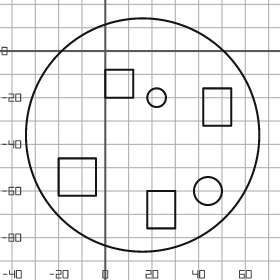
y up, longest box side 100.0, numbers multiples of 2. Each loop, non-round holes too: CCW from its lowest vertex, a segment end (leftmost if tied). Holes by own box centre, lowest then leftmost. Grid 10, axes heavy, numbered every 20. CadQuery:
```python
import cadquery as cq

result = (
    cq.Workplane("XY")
    .moveTo(16.0, -36.0)
    .circle(50.0)
    .moveTo(18.0, -76.0)
    .lineTo(30.0, -76.0)
    .lineTo(30.0, -60.0)
    .lineTo(18.0, -60.0)
    .close()
    .moveTo(44.0, -60.0)
    .circle(6.0)
    .moveTo(-20.0, -62.0)
    .lineTo(-4.0, -62.0)
    .lineTo(-4.0, -46.0)
    .lineTo(-20.0, -46.0)
    .close()
    .moveTo(42.0, -32.0)
    .lineTo(54.0, -32.0)
    .lineTo(54.0, -16.0)
    .lineTo(42.0, -16.0)
    .close()
    .moveTo(22.0, -20.0)
    .circle(4.0)
    .moveTo(0.0, -20.0)
    .lineTo(12.0, -20.0)
    .lineTo(12.0, -8.0)
    .lineTo(0.0, -8.0)
    .close()
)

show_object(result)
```